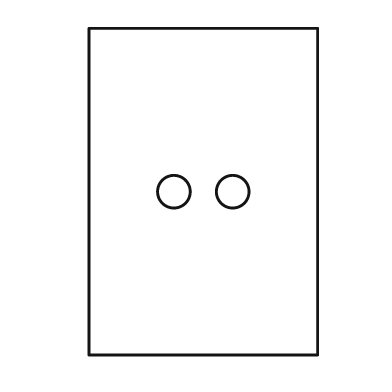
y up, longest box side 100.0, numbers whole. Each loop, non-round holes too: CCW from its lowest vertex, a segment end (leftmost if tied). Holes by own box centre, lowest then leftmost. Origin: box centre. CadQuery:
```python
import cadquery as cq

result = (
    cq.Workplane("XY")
    .moveTo(-35.0, -50.0)
    .lineTo(35.0, -50.0)
    .lineTo(35.0, 50.0)
    .lineTo(-35.0, 50.0)
    .close()
    .moveTo(-9.0, 0.0)
    .circle(5.0)
    .moveTo(9.0, 0.0)
    .circle(5.0)
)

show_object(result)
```